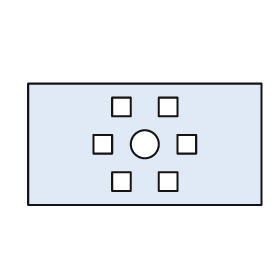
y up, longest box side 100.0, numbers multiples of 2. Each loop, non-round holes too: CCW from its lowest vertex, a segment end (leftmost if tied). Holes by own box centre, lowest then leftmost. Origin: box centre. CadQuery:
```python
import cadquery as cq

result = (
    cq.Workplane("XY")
    .moveTo(-50.0, -26.0)
    .lineTo(50.0, -26.0)
    .lineTo(50.0, 26.0)
    .lineTo(-50.0, 26.0)
    .close()
    .moveTo(-14.0, -20.0)
    .lineTo(-6.0, -20.0)
    .lineTo(-6.0, -12.0)
    .lineTo(-14.0, -12.0)
    .close()
    .moveTo(6.0, -20.0)
    .lineTo(14.0, -20.0)
    .lineTo(14.0, -12.0)
    .lineTo(6.0, -12.0)
    .close()
    .moveTo(-22.0, -4.0)
    .lineTo(-14.0, -4.0)
    .lineTo(-14.0, 4.0)
    .lineTo(-22.0, 4.0)
    .close()
    .moveTo(0.0, 0.0)
    .circle(6.0)
    .moveTo(14.0, -4.0)
    .lineTo(22.0, -4.0)
    .lineTo(22.0, 4.0)
    .lineTo(14.0, 4.0)
    .close()
    .moveTo(-14.0, 12.0)
    .lineTo(-6.0, 12.0)
    .lineTo(-6.0, 20.0)
    .lineTo(-14.0, 20.0)
    .close()
    .moveTo(6.0, 12.0)
    .lineTo(14.0, 12.0)
    .lineTo(14.0, 20.0)
    .lineTo(6.0, 20.0)
    .close()
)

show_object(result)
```